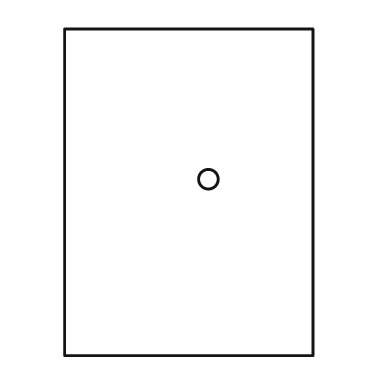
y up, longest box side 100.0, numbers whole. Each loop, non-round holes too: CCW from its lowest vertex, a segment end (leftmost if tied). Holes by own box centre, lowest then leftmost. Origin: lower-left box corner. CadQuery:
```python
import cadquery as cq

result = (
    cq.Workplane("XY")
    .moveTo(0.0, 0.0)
    .lineTo(76.0, 0.0)
    .lineTo(76.0, 100.0)
    .lineTo(0.0, 100.0)
    .close()
    .moveTo(44.0, 54.0)
    .circle(3.0)
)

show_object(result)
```